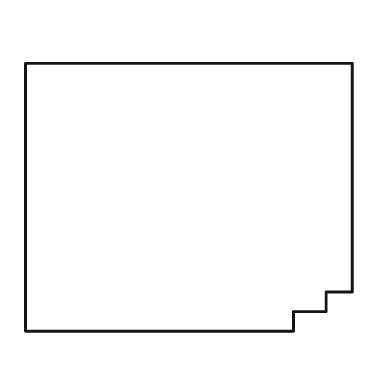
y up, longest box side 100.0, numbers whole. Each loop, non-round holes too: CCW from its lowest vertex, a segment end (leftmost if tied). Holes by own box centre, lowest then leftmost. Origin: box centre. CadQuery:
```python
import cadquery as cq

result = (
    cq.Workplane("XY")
    .moveTo(-50.0, -41.0)
    .lineTo(32.0, -41.0)
    .lineTo(32.0, -35.0)
    .lineTo(42.0, -35.0)
    .lineTo(42.0, -29.0)
    .lineTo(50.0, -29.0)
    .lineTo(50.0, 41.0)
    .lineTo(-50.0, 41.0)
    .close()
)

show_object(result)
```